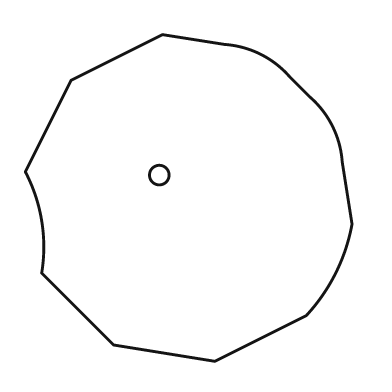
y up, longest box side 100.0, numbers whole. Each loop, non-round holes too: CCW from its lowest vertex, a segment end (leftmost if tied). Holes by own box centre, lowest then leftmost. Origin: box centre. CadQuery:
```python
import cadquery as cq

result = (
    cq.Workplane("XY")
    .moveTo(8.0, -50.0)
    .lineTo(36.0, -36.0)
    .threePointArc((45.0, -23.0), (50.0, -8.0))
    .lineTo(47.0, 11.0)
    .threePointArc((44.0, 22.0), (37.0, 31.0))
    .lineTo(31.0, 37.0)
    .threePointArc((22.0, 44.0), (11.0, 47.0))
    .lineTo(-8.0, 50.0)
    .lineTo(-36.0, 36.0)
    .lineTo(-50.0, 8.0)
    .threePointArc((-45.0, -7.0), (-45.0, -23.0))
    .lineTo(-23.0, -45.0)
    .close()
    .moveTo(-9.0, 7.0)
    .circle(3.0)
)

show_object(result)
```